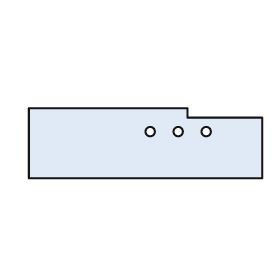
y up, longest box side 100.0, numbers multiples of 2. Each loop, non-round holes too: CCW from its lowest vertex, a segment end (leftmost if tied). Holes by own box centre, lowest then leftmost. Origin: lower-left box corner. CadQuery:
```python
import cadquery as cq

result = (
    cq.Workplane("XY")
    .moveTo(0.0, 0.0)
    .lineTo(100.0, 0.0)
    .lineTo(100.0, 26.0)
    .lineTo(68.0, 26.0)
    .lineTo(68.0, 30.0)
    .lineTo(0.0, 30.0)
    .close()
    .moveTo(52.0, 20.0)
    .circle(2.0)
    .moveTo(64.0, 20.0)
    .circle(2.0)
    .moveTo(76.0, 20.0)
    .circle(2.0)
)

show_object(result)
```